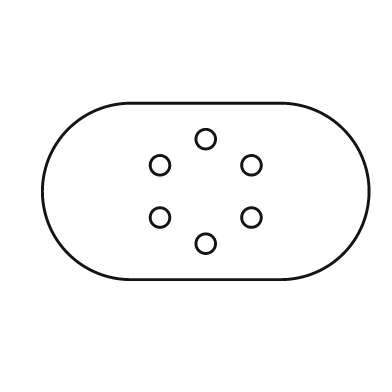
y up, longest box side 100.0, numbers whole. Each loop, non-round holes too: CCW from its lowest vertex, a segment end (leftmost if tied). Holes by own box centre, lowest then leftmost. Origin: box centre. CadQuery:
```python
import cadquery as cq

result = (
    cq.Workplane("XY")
    .moveTo(-23.0, -27.0)
    .lineTo(23.0, -27.0)
    .threePointArc((50.0, 0.0), (23.0, 27.0))
    .lineTo(-23.0, 27.0)
    .threePointArc((-50.0, 0.0), (-23.0, -27.0))
    .close()
    .moveTo(0.0, -16.0)
    .circle(3.0)
    .moveTo(-14.0, -8.0)
    .circle(3.0)
    .moveTo(14.0, -8.0)
    .circle(3.0)
    .moveTo(-14.0, 8.0)
    .circle(3.0)
    .moveTo(14.0, 8.0)
    .circle(3.0)
    .moveTo(0.0, 16.0)
    .circle(3.0)
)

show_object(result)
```